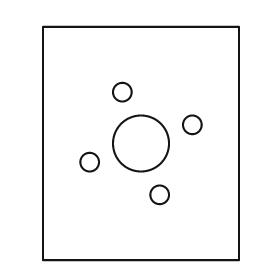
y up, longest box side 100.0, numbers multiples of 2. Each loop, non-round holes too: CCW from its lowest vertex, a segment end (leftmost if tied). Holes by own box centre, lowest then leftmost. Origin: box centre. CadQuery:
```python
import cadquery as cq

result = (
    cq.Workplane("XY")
    .moveTo(-42.0, -50.0)
    .lineTo(42.0, -50.0)
    .lineTo(42.0, 50.0)
    .lineTo(-42.0, 50.0)
    .close()
    .moveTo(8.0, -22.0)
    .circle(4.0)
    .moveTo(-22.0, -8.0)
    .circle(4.0)
    .moveTo(0.0, 0.0)
    .circle(12.0)
    .moveTo(22.0, 8.0)
    .circle(4.0)
    .moveTo(-8.0, 22.0)
    .circle(4.0)
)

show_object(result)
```